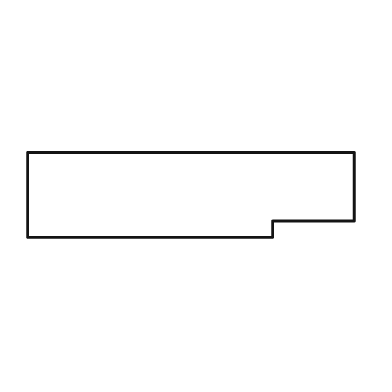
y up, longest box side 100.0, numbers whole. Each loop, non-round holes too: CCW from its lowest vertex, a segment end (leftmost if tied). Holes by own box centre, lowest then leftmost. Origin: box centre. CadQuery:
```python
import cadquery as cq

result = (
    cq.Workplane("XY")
    .moveTo(-50.0, -13.0)
    .lineTo(25.0, -13.0)
    .lineTo(25.0, -8.0)
    .lineTo(50.0, -8.0)
    .lineTo(50.0, 13.0)
    .lineTo(-50.0, 13.0)
    .close()
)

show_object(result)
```